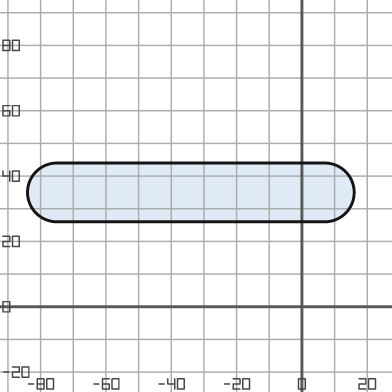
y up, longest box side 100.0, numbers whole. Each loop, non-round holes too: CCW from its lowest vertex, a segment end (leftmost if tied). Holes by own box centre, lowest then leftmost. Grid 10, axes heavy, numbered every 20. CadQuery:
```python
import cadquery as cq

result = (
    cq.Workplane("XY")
    .moveTo(-75.0, 26.0)
    .lineTo(7.0, 26.0)
    .threePointArc((16.0, 35.0), (7.0, 44.0))
    .lineTo(-75.0, 44.0)
    .threePointArc((-84.0, 35.0), (-75.0, 26.0))
    .close()
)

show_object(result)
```